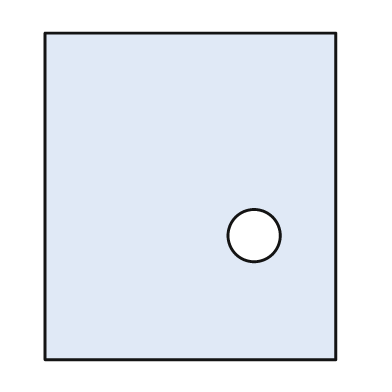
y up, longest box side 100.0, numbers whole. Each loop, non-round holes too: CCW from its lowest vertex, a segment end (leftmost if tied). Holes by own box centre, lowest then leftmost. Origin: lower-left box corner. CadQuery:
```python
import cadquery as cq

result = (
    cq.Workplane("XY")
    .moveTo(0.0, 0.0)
    .lineTo(89.0, 0.0)
    .lineTo(89.0, 100.0)
    .lineTo(0.0, 100.0)
    .close()
    .moveTo(64.0, 38.0)
    .circle(8.0)
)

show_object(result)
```